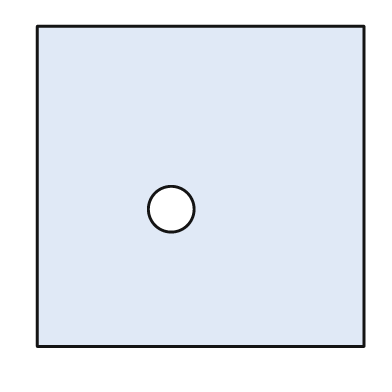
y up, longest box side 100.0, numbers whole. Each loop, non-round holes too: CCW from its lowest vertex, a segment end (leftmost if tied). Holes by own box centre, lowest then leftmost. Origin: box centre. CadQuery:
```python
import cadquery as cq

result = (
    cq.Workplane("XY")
    .moveTo(-50.0, -49.0)
    .lineTo(50.0, -49.0)
    .lineTo(50.0, 49.0)
    .lineTo(-50.0, 49.0)
    .close()
    .moveTo(-9.0, -7.0)
    .circle(7.0)
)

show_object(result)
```